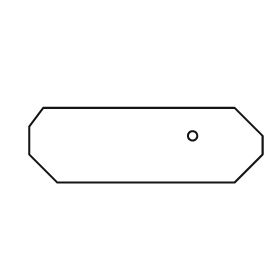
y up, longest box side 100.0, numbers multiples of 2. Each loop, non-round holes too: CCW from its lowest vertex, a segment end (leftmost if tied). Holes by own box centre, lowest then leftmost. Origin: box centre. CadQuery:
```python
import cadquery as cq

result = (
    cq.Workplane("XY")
    .moveTo(-38.0, -16.0)
    .lineTo(38.0, -16.0)
    .lineTo(50.0, -4.0)
    .lineTo(50.0, 4.0)
    .lineTo(38.0, 16.0)
    .lineTo(-44.0, 16.0)
    .lineTo(-50.0, 8.0)
    .lineTo(-50.0, -4.0)
    .close()
    .moveTo(20.0, 4.0)
    .circle(2.0)
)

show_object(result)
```